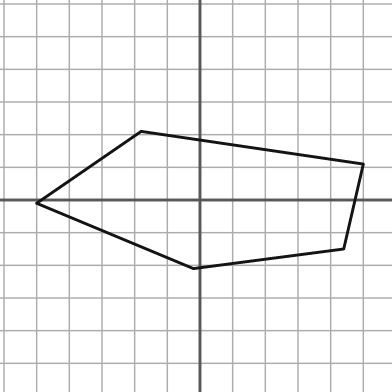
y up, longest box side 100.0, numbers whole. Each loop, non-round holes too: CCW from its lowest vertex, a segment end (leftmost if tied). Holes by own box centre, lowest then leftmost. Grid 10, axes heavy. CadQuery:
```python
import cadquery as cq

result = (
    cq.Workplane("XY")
    .moveTo(-2.0, -21.0)
    .lineTo(44.0, -15.0)
    .lineTo(50.0, 11.0)
    .lineTo(-18.0, 21.0)
    .lineTo(-50.0, -1.0)
    .close()
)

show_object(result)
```